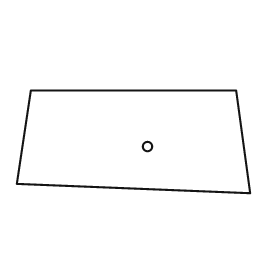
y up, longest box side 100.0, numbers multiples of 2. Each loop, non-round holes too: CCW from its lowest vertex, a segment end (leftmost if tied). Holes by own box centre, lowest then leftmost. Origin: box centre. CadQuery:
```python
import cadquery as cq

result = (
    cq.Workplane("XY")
    .moveTo(50.0, -22.0)
    .lineTo(44.0, 22.0)
    .lineTo(-44.0, 22.0)
    .lineTo(-50.0, -18.0)
    .close()
    .moveTo(6.0, -2.0)
    .circle(2.0)
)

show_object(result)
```